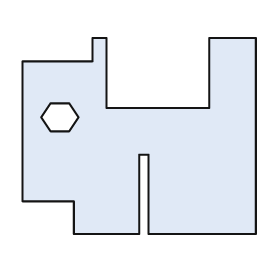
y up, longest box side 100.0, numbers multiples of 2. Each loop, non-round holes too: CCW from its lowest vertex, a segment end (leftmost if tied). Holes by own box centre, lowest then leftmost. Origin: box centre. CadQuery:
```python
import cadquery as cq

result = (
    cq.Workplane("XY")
    .moveTo(-28.0, -42.0)
    .lineTo(0.0, -42.0)
    .lineTo(0.0, -8.0)
    .lineTo(4.0, -8.0)
    .lineTo(4.0, -42.0)
    .lineTo(50.0, -42.0)
    .lineTo(50.0, 42.0)
    .lineTo(30.0, 42.0)
    .lineTo(30.0, 12.0)
    .lineTo(-14.0, 12.0)
    .lineTo(-14.0, 42.0)
    .lineTo(-20.0, 42.0)
    .lineTo(-20.0, 32.0)
    .lineTo(-50.0, 32.0)
    .lineTo(-50.0, -28.0)
    .lineTo(-28.0, -28.0)
    .close()
    .moveTo(-38.0, 2.0)
    .lineTo(-30.0, 2.0)
    .lineTo(-26.0, 8.0)
    .lineTo(-30.0, 14.0)
    .lineTo(-38.0, 14.0)
    .lineTo(-42.0, 8.0)
    .close()
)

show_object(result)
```